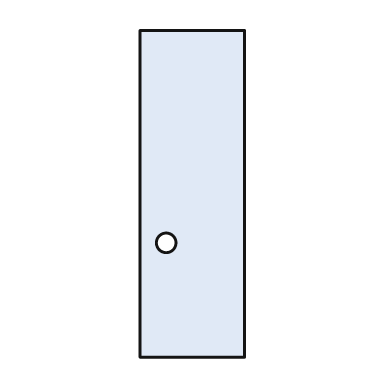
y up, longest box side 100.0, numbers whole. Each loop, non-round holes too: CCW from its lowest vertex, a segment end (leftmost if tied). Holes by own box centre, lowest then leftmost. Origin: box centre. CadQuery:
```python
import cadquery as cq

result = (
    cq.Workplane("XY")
    .moveTo(-16.0, -50.0)
    .lineTo(16.0, -50.0)
    .lineTo(16.0, 50.0)
    .lineTo(-16.0, 50.0)
    .close()
    .moveTo(-8.0, -15.0)
    .circle(3.0)
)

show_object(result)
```